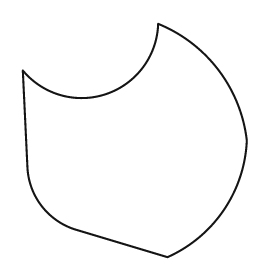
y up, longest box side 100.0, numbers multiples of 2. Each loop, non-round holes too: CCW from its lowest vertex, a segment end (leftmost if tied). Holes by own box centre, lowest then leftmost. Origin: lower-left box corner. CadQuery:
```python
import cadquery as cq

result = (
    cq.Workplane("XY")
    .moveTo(62.0, 0.0)
    .threePointArc((86.0, 20.0), (96.0, 50.0))
    .threePointArc((84.0, 80.0), (58.0, 100.0))
    .threePointArc((36.0, 70.0), (0.0, 80.0))
    .lineTo(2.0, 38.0)
    .threePointArc((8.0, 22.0), (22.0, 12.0))
    .close()
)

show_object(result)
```